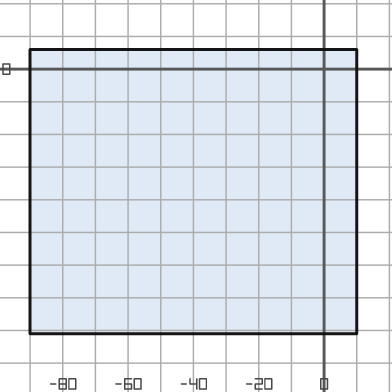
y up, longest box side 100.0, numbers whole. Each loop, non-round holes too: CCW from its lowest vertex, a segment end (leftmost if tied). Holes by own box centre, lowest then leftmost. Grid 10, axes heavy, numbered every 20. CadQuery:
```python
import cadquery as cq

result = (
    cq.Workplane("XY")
    .moveTo(-90.0, -81.0)
    .lineTo(10.0, -81.0)
    .lineTo(10.0, 6.0)
    .lineTo(-90.0, 6.0)
    .close()
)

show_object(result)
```